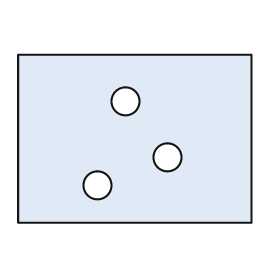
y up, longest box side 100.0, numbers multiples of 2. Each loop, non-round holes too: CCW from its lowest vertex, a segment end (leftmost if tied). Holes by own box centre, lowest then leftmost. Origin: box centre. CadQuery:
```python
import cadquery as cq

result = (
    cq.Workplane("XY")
    .moveTo(-50.0, -36.0)
    .lineTo(50.0, -36.0)
    .lineTo(50.0, 36.0)
    .lineTo(-50.0, 36.0)
    .close()
    .moveTo(-16.0, -20.0)
    .circle(6.0)
    .moveTo(14.0, -8.0)
    .circle(6.0)
    .moveTo(-4.0, 16.0)
    .circle(6.0)
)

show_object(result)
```